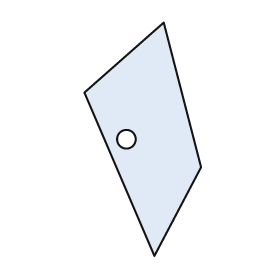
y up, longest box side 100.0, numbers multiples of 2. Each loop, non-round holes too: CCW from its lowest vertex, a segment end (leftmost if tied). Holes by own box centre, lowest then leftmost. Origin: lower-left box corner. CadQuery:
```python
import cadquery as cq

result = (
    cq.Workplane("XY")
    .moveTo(30.0, 0.0)
    .lineTo(50.0, 38.0)
    .lineTo(34.0, 100.0)
    .lineTo(0.0, 70.0)
    .close()
    .moveTo(18.0, 50.0)
    .circle(4.0)
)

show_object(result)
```